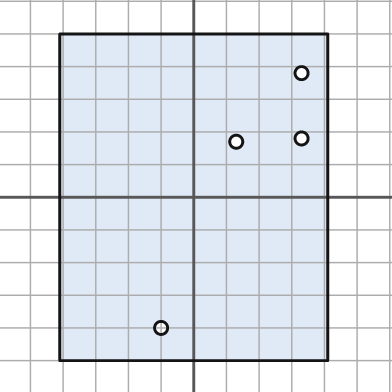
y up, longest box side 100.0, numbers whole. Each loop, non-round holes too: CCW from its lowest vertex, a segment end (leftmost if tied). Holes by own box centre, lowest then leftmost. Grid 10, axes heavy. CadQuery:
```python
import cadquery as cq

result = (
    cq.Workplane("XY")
    .moveTo(-41.0, -50.0)
    .lineTo(41.0, -50.0)
    .lineTo(41.0, 50.0)
    .lineTo(-41.0, 50.0)
    .close()
    .moveTo(-10.0, -40.0)
    .circle(2.0)
    .moveTo(13.0, 17.0)
    .circle(2.0)
    .moveTo(33.0, 18.0)
    .circle(2.0)
    .moveTo(33.0, 38.0)
    .circle(2.0)
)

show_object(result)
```